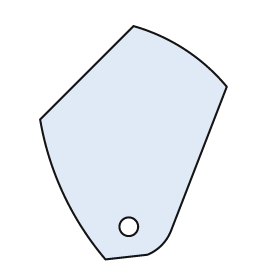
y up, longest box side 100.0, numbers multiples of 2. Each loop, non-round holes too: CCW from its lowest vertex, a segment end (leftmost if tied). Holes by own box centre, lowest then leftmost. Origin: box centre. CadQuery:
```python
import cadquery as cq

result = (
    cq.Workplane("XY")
    .moveTo(-12.0, -50.0)
    .lineTo(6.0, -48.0)
    .threePointArc((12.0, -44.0), (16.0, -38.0))
    .lineTo(40.0, 24.0)
    .threePointArc((22.0, 40.0), (0.0, 50.0))
    .lineTo(-40.0, 10.0)
    .threePointArc((-30.0, -22.0), (-12.0, -50.0))
    .close()
    .moveTo(-2.0, -36.0)
    .circle(4.0)
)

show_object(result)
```